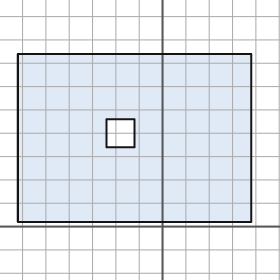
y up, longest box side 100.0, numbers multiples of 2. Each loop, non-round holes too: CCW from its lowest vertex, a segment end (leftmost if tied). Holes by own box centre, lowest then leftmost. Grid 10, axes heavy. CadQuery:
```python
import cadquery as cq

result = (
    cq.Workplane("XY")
    .moveTo(-62.0, 2.0)
    .lineTo(38.0, 2.0)
    .lineTo(38.0, 74.0)
    .lineTo(-62.0, 74.0)
    .close()
    .moveTo(-24.0, 34.0)
    .lineTo(-12.0, 34.0)
    .lineTo(-12.0, 46.0)
    .lineTo(-24.0, 46.0)
    .close()
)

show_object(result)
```